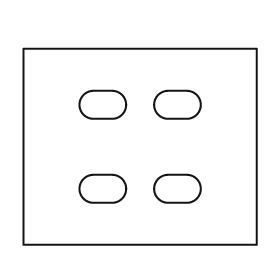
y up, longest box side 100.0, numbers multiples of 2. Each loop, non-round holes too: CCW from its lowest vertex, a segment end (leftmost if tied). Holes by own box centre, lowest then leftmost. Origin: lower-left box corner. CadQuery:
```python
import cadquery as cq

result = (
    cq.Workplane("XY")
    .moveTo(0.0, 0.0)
    .lineTo(100.0, 0.0)
    .lineTo(100.0, 84.0)
    .lineTo(0.0, 84.0)
    .close()
    .moveTo(30.0, 18.0)
    .lineTo(38.0, 18.0)
    .threePointArc((44.0, 24.0), (38.0, 30.0))
    .lineTo(30.0, 30.0)
    .threePointArc((24.0, 24.0), (30.0, 18.0))
    .close()
    .moveTo(62.0, 18.0)
    .lineTo(70.0, 18.0)
    .threePointArc((76.0, 24.0), (70.0, 30.0))
    .lineTo(62.0, 30.0)
    .threePointArc((56.0, 24.0), (62.0, 18.0))
    .close()
    .moveTo(30.0, 54.0)
    .lineTo(38.0, 54.0)
    .threePointArc((44.0, 60.0), (38.0, 66.0))
    .lineTo(30.0, 66.0)
    .threePointArc((24.0, 60.0), (30.0, 54.0))
    .close()
    .moveTo(62.0, 54.0)
    .lineTo(70.0, 54.0)
    .threePointArc((76.0, 60.0), (70.0, 66.0))
    .lineTo(62.0, 66.0)
    .threePointArc((56.0, 60.0), (62.0, 54.0))
    .close()
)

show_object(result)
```